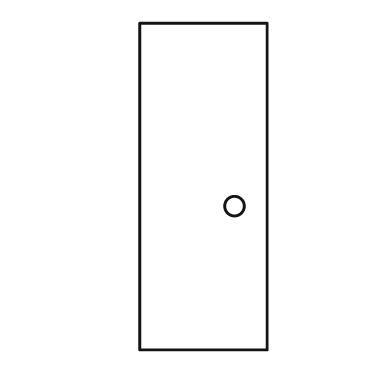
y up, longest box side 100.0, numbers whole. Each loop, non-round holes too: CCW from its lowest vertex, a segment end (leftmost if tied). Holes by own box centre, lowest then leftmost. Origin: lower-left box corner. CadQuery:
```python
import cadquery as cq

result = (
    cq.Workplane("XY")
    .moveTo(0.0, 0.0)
    .lineTo(39.0, 0.0)
    .lineTo(39.0, 100.0)
    .lineTo(0.0, 100.0)
    .close()
    .moveTo(29.0, 44.0)
    .circle(3.0)
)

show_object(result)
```